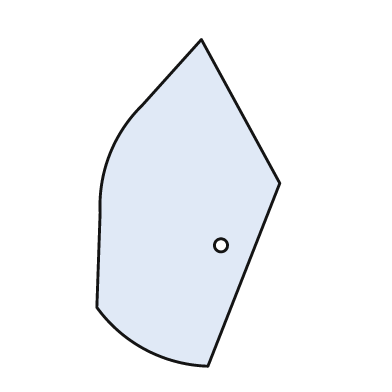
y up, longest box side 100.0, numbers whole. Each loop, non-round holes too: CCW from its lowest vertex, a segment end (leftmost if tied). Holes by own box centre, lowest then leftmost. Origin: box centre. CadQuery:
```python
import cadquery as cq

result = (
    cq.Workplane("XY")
    .moveTo(6.0, -50.0)
    .lineTo(28.0, 6.0)
    .lineTo(4.0, 50.0)
    .lineTo(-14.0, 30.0)
    .threePointArc((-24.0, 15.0), (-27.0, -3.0))
    .lineTo(-28.0, -32.0)
    .threePointArc((-13.0, -45.0), (6.0, -50.0))
    .close()
    .moveTo(10.0, -13.0)
    .circle(2.0)
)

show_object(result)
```